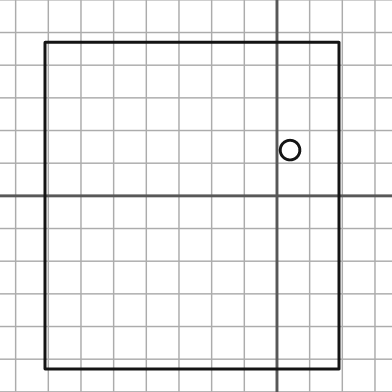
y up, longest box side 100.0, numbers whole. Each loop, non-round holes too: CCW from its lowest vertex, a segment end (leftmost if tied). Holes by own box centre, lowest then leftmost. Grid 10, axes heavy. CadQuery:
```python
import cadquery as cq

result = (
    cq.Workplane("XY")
    .moveTo(-71.0, -53.0)
    .lineTo(19.0, -53.0)
    .lineTo(19.0, 47.0)
    .lineTo(-71.0, 47.0)
    .close()
    .moveTo(4.0, 14.0)
    .circle(3.0)
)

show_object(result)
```